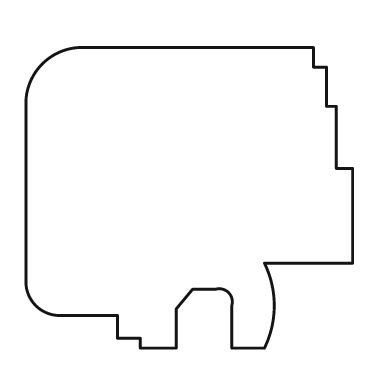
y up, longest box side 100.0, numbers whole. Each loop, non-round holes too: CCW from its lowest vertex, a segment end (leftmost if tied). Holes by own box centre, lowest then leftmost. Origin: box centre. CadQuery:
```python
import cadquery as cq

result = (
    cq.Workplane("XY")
    .moveTo(-15.0, -46.0)
    .lineTo(-4.0, -46.0)
    .lineTo(-4.0, -34.0)
    .lineTo(1.0, -28.0)
    .lineTo(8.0, -28.0)
    .threePointArc((12.0, -29.0), (13.0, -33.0))
    .lineTo(13.0, -46.0)
    .lineTo(23.0, -46.0)
    .threePointArc((26.0, -33.0), (23.0, -20.0))
    .lineTo(50.0, -20.0)
    .lineTo(50.0, 9.0)
    .lineTo(45.0, 9.0)
    .lineTo(45.0, 28.0)
    .lineTo(42.0, 28.0)
    .lineTo(42.0, 40.0)
    .lineTo(38.0, 40.0)
    .lineTo(38.0, 46.0)
    .lineTo(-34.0, 46.0)
    .threePointArc((-45.0, 41.0), (-50.0, 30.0))
    .lineTo(-50.0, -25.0)
    .threePointArc((-47.0, -33.0), (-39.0, -36.0))
    .lineTo(-22.0, -36.0)
    .lineTo(-22.0, -43.0)
    .lineTo(-15.0, -43.0)
    .close()
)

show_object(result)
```